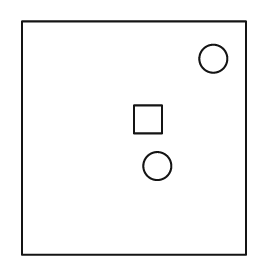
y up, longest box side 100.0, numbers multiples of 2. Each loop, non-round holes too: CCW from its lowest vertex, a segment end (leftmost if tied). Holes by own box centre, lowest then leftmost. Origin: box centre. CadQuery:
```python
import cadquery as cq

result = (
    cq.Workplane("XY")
    .moveTo(-48.0, -50.0)
    .lineTo(48.0, -50.0)
    .lineTo(48.0, 50.0)
    .lineTo(-48.0, 50.0)
    .close()
    .moveTo(10.0, -12.0)
    .circle(6.0)
    .moveTo(0.0, 2.0)
    .lineTo(12.0, 2.0)
    .lineTo(12.0, 14.0)
    .lineTo(0.0, 14.0)
    .close()
    .moveTo(34.0, 34.0)
    .circle(6.0)
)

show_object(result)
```